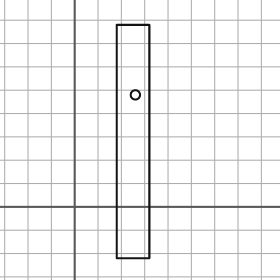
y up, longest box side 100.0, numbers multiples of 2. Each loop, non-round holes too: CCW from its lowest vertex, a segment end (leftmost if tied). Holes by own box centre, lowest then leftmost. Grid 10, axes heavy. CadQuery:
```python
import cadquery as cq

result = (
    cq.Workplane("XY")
    .moveTo(18.0, -22.0)
    .lineTo(32.0, -22.0)
    .lineTo(32.0, 78.0)
    .lineTo(18.0, 78.0)
    .close()
    .moveTo(26.0, 48.0)
    .circle(2.0)
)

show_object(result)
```